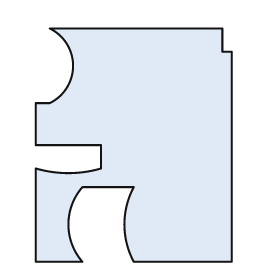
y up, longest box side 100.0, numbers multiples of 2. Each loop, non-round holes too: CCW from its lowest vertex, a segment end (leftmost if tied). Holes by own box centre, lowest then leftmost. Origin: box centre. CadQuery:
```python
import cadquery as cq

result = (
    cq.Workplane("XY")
    .moveTo(-42.0, -50.0)
    .lineTo(-22.0, -50.0)
    .threePointArc((-28.0, -34.0), (-22.0, -18.0))
    .lineTo(0.0, -18.0)
    .threePointArc((-4.0, -34.0), (0.0, -50.0))
    .lineTo(42.0, -50.0)
    .lineTo(42.0, 40.0)
    .lineTo(38.0, 40.0)
    .lineTo(38.0, 50.0)
    .lineTo(-36.0, 50.0)
    .threePointArc((-26.0, 34.0), (-36.0, 18.0))
    .lineTo(-42.0, 18.0)
    .lineTo(-42.0, 0.0)
    .lineTo(-14.0, 0.0)
    .lineTo(-14.0, -10.0)
    .threePointArc((-28.0, -12.0), (-42.0, -10.0))
    .close()
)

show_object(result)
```